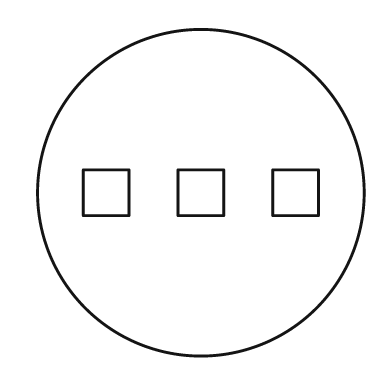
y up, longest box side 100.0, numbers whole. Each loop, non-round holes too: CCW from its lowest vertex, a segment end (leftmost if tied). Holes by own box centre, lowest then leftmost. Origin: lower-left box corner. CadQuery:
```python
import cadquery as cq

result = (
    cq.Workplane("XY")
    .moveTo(50.0, 50.0)
    .circle(50.0)
    .moveTo(14.0, 43.0)
    .lineTo(28.0, 43.0)
    .lineTo(28.0, 57.0)
    .lineTo(14.0, 57.0)
    .close()
    .moveTo(43.0, 43.0)
    .lineTo(57.0, 43.0)
    .lineTo(57.0, 57.0)
    .lineTo(43.0, 57.0)
    .close()
    .moveTo(72.0, 43.0)
    .lineTo(86.0, 43.0)
    .lineTo(86.0, 57.0)
    .lineTo(72.0, 57.0)
    .close()
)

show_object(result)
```